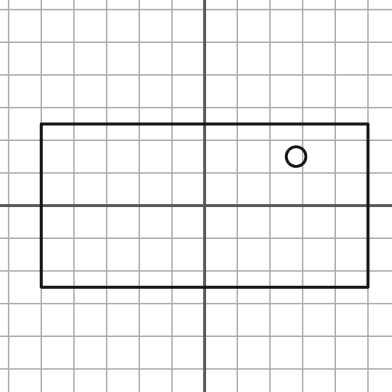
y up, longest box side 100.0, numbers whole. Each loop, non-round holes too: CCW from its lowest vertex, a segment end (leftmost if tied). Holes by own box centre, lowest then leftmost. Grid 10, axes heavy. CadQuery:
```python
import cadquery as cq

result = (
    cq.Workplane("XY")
    .moveTo(-50.0, -25.0)
    .lineTo(50.0, -25.0)
    .lineTo(50.0, 25.0)
    .lineTo(-50.0, 25.0)
    .close()
    .moveTo(28.0, 15.0)
    .circle(3.0)
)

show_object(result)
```